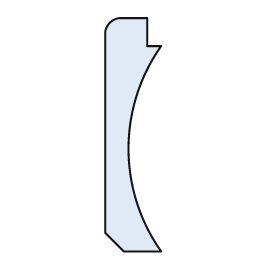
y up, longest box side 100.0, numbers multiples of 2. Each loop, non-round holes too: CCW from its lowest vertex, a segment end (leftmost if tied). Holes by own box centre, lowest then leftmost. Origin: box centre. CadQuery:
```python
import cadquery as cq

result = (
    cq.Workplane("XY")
    .moveTo(-4.0, -50.0)
    .lineTo(12.0, -50.0)
    .threePointArc((-2.0, -6.0), (12.0, 38.0))
    .lineTo(6.0, 38.0)
    .lineTo(6.0, 50.0)
    .lineTo(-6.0, 50.0)
    .threePointArc((-10.0, 48.0), (-12.0, 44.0))
    .lineTo(-12.0, -42.0)
    .close()
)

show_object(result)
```